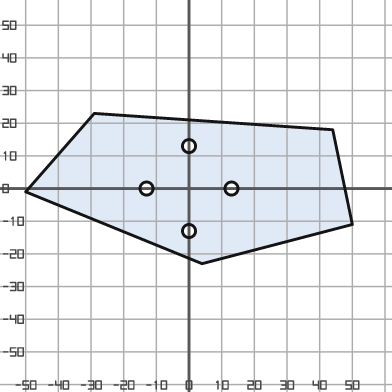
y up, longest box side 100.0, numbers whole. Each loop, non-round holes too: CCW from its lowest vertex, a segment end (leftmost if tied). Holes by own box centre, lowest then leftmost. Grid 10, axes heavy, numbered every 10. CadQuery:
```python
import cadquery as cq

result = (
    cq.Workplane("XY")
    .moveTo(4.0, -23.0)
    .lineTo(50.0, -11.0)
    .lineTo(44.0, 18.0)
    .lineTo(-29.0, 23.0)
    .lineTo(-50.0, -1.0)
    .close()
    .moveTo(0.0, -13.0)
    .circle(2.0)
    .moveTo(-13.0, 0.0)
    .circle(2.0)
    .moveTo(13.0, 0.0)
    .circle(2.0)
    .moveTo(0.0, 13.0)
    .circle(2.0)
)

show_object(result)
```